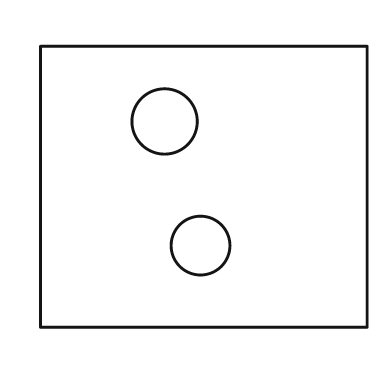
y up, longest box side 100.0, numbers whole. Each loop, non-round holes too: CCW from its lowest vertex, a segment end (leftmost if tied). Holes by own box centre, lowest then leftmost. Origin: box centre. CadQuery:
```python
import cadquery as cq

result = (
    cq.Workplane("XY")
    .moveTo(-50.0, -43.0)
    .lineTo(50.0, -43.0)
    .lineTo(50.0, 43.0)
    .lineTo(-50.0, 43.0)
    .close()
    .moveTo(-1.0, -18.0)
    .circle(9.0)
    .moveTo(-12.0, 20.0)
    .circle(10.0)
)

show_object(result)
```